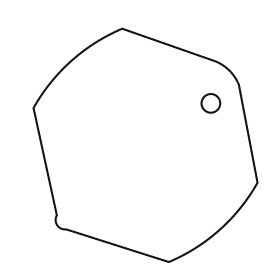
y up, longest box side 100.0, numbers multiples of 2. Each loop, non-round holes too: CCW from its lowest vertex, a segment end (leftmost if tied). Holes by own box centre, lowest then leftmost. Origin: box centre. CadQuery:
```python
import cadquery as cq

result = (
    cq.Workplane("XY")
    .moveTo(10.0, -50.0)
    .threePointArc((32.0, -36.0), (48.0, -16.0))
    .lineTo(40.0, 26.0)
    .threePointArc((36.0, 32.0), (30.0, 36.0))
    .lineTo(-10.0, 50.0)
    .threePointArc((-32.0, 36.0), (-48.0, 16.0))
    .lineTo(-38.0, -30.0)
    .threePointArc((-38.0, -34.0), (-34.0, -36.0))
    .close()
    .moveTo(28.0, 18.0)
    .circle(4.0)
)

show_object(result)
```